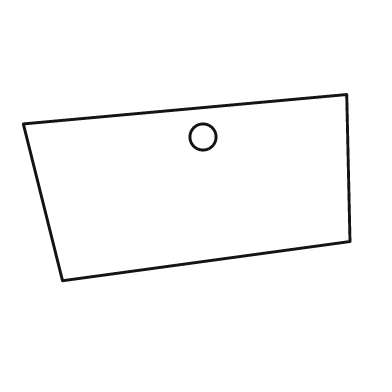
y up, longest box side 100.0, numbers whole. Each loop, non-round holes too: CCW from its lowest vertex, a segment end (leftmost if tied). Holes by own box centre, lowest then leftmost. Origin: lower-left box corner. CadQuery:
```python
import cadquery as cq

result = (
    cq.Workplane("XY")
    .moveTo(12.0, 0.0)
    .lineTo(100.0, 12.0)
    .lineTo(99.0, 57.0)
    .lineTo(0.0, 48.0)
    .close()
    .moveTo(55.0, 44.0)
    .circle(4.0)
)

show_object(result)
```